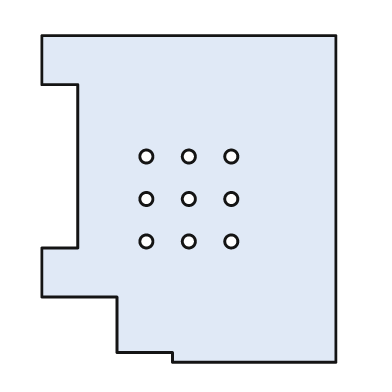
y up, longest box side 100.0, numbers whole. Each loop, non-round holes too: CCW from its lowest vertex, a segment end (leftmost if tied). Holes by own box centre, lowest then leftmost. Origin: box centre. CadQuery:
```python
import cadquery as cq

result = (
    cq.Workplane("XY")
    .moveTo(-5.0, -50.0)
    .lineTo(45.0, -50.0)
    .lineTo(45.0, 50.0)
    .lineTo(-45.0, 50.0)
    .lineTo(-45.0, 35.0)
    .lineTo(-34.0, 35.0)
    .lineTo(-34.0, -15.0)
    .lineTo(-45.0, -15.0)
    .lineTo(-45.0, -30.0)
    .lineTo(-22.0, -30.0)
    .lineTo(-22.0, -47.0)
    .lineTo(-5.0, -47.0)
    .close()
    .moveTo(-13.0, -13.0)
    .circle(2.0)
    .moveTo(0.0, -13.0)
    .circle(2.0)
    .moveTo(13.0, -13.0)
    .circle(2.0)
    .moveTo(-13.0, 0.0)
    .circle(2.0)
    .moveTo(0.0, 0.0)
    .circle(2.0)
    .moveTo(13.0, 0.0)
    .circle(2.0)
    .moveTo(-13.0, 13.0)
    .circle(2.0)
    .moveTo(0.0, 13.0)
    .circle(2.0)
    .moveTo(13.0, 13.0)
    .circle(2.0)
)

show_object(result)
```